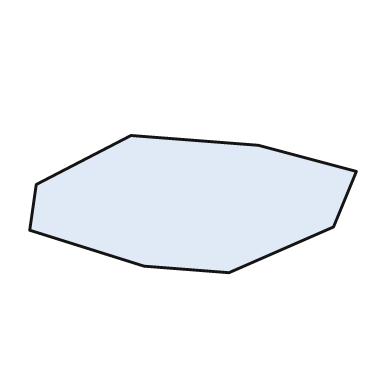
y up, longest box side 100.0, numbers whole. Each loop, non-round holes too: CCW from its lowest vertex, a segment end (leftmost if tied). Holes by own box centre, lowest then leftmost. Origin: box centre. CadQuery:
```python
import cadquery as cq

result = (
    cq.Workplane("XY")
    .moveTo(11.0, -21.0)
    .lineTo(43.0, -7.0)
    .lineTo(50.0, 10.0)
    .lineTo(20.0, 18.0)
    .lineTo(-19.0, 21.0)
    .lineTo(-48.0, 6.0)
    .lineTo(-50.0, -8.0)
    .lineTo(-15.0, -19.0)
    .close()
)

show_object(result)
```